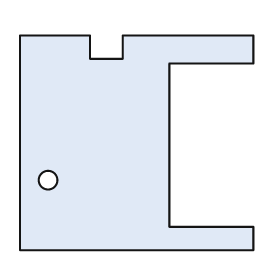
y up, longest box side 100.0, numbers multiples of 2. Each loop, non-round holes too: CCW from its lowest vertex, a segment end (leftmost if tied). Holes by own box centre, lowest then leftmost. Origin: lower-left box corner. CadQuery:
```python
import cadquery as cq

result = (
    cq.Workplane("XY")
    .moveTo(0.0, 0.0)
    .lineTo(100.0, 0.0)
    .lineTo(100.0, 10.0)
    .lineTo(64.0, 10.0)
    .lineTo(64.0, 80.0)
    .lineTo(100.0, 80.0)
    .lineTo(100.0, 92.0)
    .lineTo(44.0, 92.0)
    .lineTo(44.0, 82.0)
    .lineTo(30.0, 82.0)
    .lineTo(30.0, 92.0)
    .lineTo(0.0, 92.0)
    .close()
    .moveTo(12.0, 30.0)
    .circle(4.0)
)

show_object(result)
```